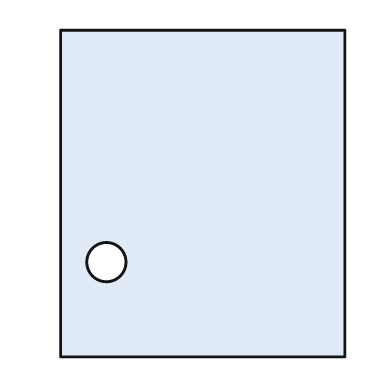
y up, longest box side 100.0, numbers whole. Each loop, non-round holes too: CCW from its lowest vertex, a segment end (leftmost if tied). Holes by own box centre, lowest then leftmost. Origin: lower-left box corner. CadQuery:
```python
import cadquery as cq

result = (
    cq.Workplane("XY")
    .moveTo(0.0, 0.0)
    .lineTo(87.0, 0.0)
    .lineTo(87.0, 100.0)
    .lineTo(0.0, 100.0)
    .close()
    .moveTo(14.0, 29.0)
    .circle(6.0)
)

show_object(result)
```